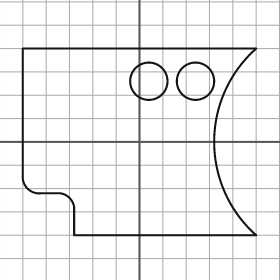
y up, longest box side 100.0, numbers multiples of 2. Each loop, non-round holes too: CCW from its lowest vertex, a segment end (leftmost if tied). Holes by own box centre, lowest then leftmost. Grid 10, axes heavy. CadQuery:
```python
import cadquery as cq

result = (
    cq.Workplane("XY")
    .moveTo(-28.0, -40.0)
    .lineTo(50.0, -40.0)
    .threePointArc((32.0, 0.0), (50.0, 40.0))
    .lineTo(-50.0, 40.0)
    .lineTo(-50.0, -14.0)
    .threePointArc((-48.0, -20.0), (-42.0, -22.0))
    .lineTo(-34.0, -22.0)
    .threePointArc((-30.0, -24.0), (-28.0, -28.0))
    .close()
    .moveTo(4.0, 26.0)
    .circle(8.0)
    .moveTo(24.0, 26.0)
    .circle(8.0)
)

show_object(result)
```